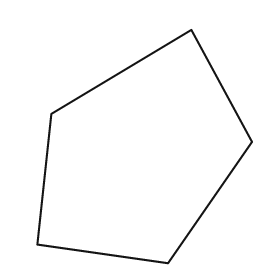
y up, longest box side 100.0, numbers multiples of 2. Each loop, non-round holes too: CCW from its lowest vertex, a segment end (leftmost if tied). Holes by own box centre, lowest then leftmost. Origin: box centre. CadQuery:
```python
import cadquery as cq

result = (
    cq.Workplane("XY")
    .moveTo(10.0, -50.0)
    .lineTo(46.0, 2.0)
    .lineTo(20.0, 50.0)
    .lineTo(-40.0, 14.0)
    .lineTo(-46.0, -42.0)
    .close()
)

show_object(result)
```